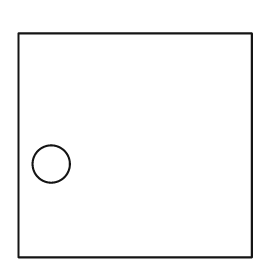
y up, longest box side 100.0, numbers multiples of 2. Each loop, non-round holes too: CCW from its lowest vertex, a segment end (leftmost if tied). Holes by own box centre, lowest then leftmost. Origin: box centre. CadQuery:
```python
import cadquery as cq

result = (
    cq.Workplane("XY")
    .moveTo(-50.0, -48.0)
    .lineTo(50.0, -48.0)
    .lineTo(50.0, 48.0)
    .lineTo(-50.0, 48.0)
    .close()
    .moveTo(-36.0, -8.0)
    .circle(8.0)
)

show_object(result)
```